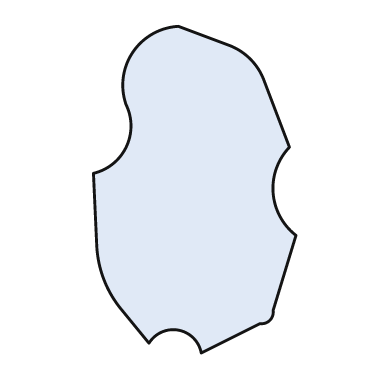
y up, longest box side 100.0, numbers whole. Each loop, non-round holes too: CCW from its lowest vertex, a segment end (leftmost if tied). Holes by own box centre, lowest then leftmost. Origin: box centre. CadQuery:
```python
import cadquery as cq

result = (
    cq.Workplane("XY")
    .moveTo(2.0, -50.0)
    .lineTo(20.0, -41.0)
    .threePointArc((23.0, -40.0), (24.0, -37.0))
    .lineTo(31.0, -14.0)
    .threePointArc((24.0, -1.0), (29.0, 13.0))
    .lineTo(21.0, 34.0)
    .threePointArc((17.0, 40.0), (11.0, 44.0))
    .lineTo(-5.0, 50.0)
    .threePointArc((-19.0, 42.0), (-21.0, 26.0))
    .threePointArc((-21.0, 13.0), (-31.0, 5.0))
    .lineTo(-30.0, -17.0)
    .threePointArc((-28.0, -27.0), (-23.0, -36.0))
    .lineTo(-14.0, -47.0)
    .threePointArc((-5.0, -43.0), (2.0, -50.0))
    .close()
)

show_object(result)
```